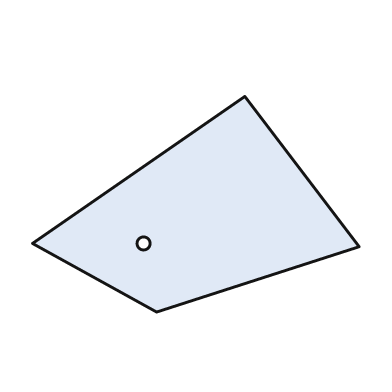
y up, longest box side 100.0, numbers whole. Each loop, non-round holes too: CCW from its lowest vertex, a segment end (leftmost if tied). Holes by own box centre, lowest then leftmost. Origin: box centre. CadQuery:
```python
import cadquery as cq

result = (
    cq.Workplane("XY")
    .moveTo(-12.0, -33.0)
    .lineTo(50.0, -13.0)
    .lineTo(15.0, 33.0)
    .lineTo(-50.0, -12.0)
    .close()
    .moveTo(-16.0, -12.0)
    .circle(2.0)
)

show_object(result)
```